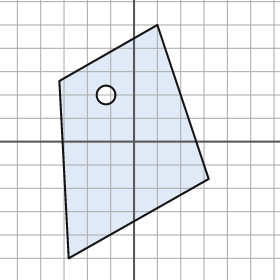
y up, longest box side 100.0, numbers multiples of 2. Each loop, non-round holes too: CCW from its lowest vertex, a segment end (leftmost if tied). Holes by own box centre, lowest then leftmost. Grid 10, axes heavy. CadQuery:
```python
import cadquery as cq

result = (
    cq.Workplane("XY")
    .moveTo(-28.0, -50.0)
    .lineTo(32.0, -16.0)
    .lineTo(10.0, 50.0)
    .lineTo(-32.0, 26.0)
    .close()
    .moveTo(-12.0, 20.0)
    .circle(4.0)
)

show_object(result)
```